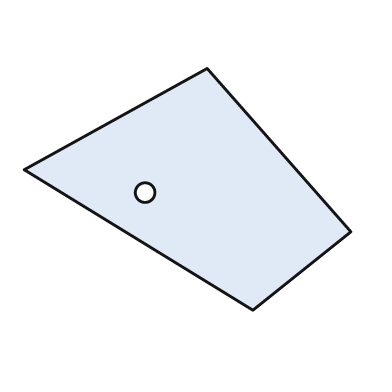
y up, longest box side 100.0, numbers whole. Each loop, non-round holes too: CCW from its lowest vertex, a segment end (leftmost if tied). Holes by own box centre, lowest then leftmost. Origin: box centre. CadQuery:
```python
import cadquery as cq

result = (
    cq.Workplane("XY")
    .moveTo(20.0, -37.0)
    .lineTo(50.0, -13.0)
    .lineTo(6.0, 37.0)
    .lineTo(-50.0, 6.0)
    .close()
    .moveTo(-13.0, -1.0)
    .circle(3.0)
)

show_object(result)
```